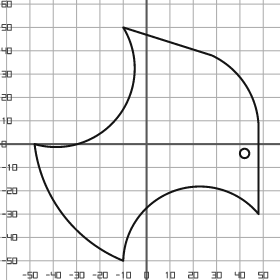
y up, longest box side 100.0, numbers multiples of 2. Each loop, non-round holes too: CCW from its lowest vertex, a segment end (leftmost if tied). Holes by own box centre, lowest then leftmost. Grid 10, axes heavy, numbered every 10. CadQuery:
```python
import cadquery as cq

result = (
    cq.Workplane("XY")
    .moveTo(-10.0, -50.0)
    .threePointArc((12.0, -20.0), (48.0, -30.0))
    .lineTo(48.0, 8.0)
    .threePointArc((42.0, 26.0), (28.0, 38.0))
    .lineTo(-10.0, 50.0)
    .threePointArc((-12.0, 12.0), (-48.0, 0.0))
    .threePointArc((-36.0, -30.0), (-10.0, -50.0))
    .close()
    .moveTo(42.0, -4.0)
    .circle(2.0)
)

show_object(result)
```